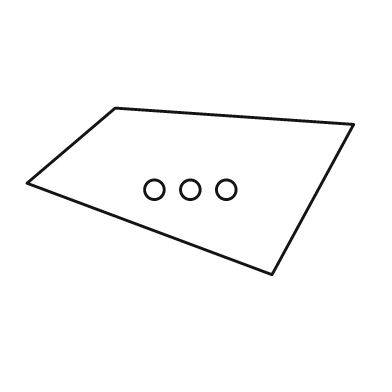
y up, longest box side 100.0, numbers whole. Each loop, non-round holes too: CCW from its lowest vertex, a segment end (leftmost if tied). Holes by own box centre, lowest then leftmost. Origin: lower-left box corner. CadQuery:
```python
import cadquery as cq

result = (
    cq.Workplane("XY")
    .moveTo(75.0, 0.0)
    .lineTo(100.0, 46.0)
    .lineTo(27.0, 51.0)
    .lineTo(0.0, 28.0)
    .close()
    .moveTo(39.0, 26.0)
    .circle(3.0)
    .moveTo(50.0, 26.0)
    .circle(3.0)
    .moveTo(61.0, 26.0)
    .circle(3.0)
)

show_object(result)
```